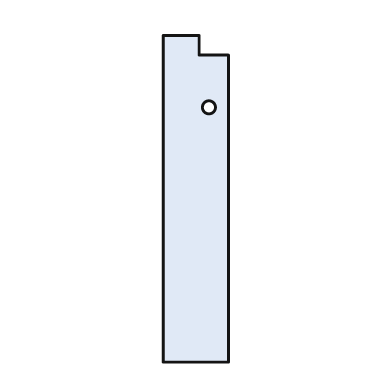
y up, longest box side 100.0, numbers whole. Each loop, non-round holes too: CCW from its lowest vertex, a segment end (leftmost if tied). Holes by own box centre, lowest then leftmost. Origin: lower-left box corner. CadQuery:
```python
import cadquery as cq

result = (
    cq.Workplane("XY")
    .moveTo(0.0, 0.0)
    .lineTo(20.0, 0.0)
    .lineTo(20.0, 94.0)
    .lineTo(11.0, 94.0)
    .lineTo(11.0, 100.0)
    .lineTo(0.0, 100.0)
    .close()
    .moveTo(14.0, 78.0)
    .circle(2.0)
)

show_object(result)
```